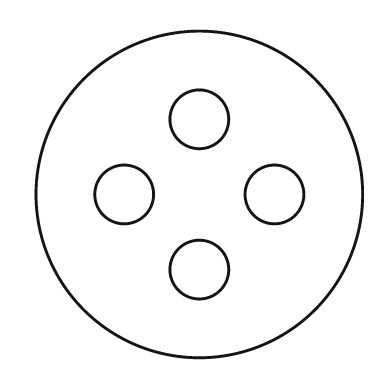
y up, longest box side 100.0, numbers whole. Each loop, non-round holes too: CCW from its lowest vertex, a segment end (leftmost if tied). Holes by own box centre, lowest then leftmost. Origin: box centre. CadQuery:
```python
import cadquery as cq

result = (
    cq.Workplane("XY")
    .moveTo(0.0, 0.0)
    .circle(50.0)
    .moveTo(0.0, -23.0)
    .circle(9.0)
    .moveTo(-23.0, 0.0)
    .circle(9.0)
    .moveTo(23.0, 0.0)
    .circle(9.0)
    .moveTo(0.0, 23.0)
    .circle(9.0)
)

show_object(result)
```